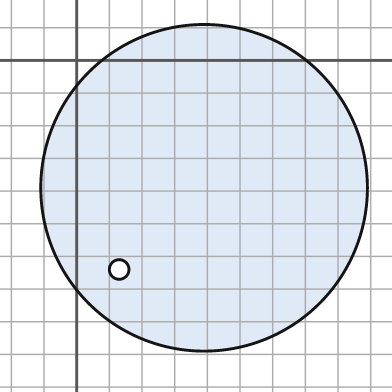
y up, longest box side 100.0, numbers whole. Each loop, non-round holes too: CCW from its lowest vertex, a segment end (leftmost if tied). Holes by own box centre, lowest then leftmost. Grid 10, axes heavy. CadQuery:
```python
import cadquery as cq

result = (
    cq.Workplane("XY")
    .moveTo(39.0, -39.0)
    .circle(50.0)
    .moveTo(13.0, -64.0)
    .circle(3.0)
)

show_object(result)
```